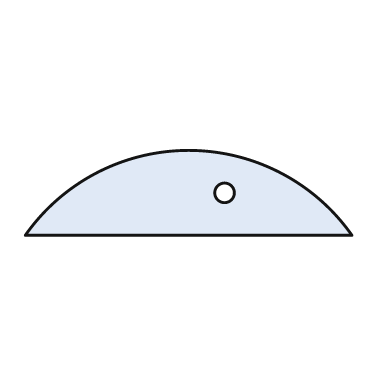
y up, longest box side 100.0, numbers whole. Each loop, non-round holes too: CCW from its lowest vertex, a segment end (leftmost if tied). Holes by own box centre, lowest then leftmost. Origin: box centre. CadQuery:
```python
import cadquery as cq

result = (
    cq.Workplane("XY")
    .moveTo(-50.0, -13.0)
    .lineTo(50.0, -13.0)
    .threePointArc((0.0, 13.0), (-50.0, -13.0))
    .close()
    .moveTo(11.0, 0.0)
    .circle(3.0)
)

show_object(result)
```